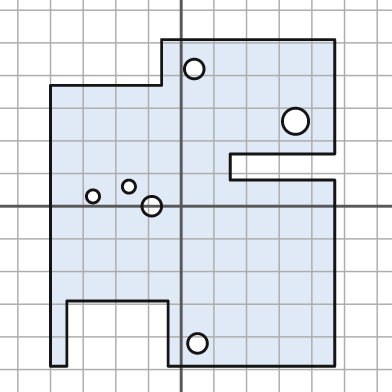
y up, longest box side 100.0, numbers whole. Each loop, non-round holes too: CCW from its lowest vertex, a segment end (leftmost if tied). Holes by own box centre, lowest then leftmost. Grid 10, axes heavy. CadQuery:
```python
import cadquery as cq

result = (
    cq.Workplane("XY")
    .moveTo(-40.0, -49.0)
    .lineTo(-35.0, -49.0)
    .lineTo(-35.0, -29.0)
    .lineTo(-4.0, -29.0)
    .lineTo(-4.0, -49.0)
    .lineTo(47.0, -49.0)
    .lineTo(47.0, 8.0)
    .lineTo(15.0, 8.0)
    .lineTo(15.0, 16.0)
    .lineTo(47.0, 16.0)
    .lineTo(47.0, 51.0)
    .lineTo(-6.0, 51.0)
    .lineTo(-6.0, 37.0)
    .lineTo(-40.0, 37.0)
    .close()
    .moveTo(5.0, -42.0)
    .circle(3.0)
    .moveTo(-9.0, 0.0)
    .circle(3.0)
    .moveTo(-27.0, 3.0)
    .circle(2.0)
    .moveTo(-16.0, 6.0)
    .circle(2.0)
    .moveTo(35.0, 26.0)
    .circle(4.0)
    .moveTo(4.0, 42.0)
    .circle(3.0)
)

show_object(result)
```